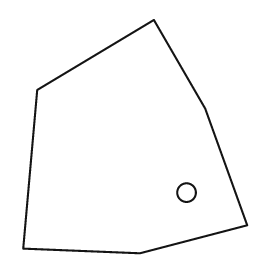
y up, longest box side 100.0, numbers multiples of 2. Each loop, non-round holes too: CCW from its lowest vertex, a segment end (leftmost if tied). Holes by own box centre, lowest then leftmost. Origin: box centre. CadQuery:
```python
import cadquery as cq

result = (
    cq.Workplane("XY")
    .moveTo(2.0, -50.0)
    .lineTo(48.0, -38.0)
    .lineTo(30.0, 12.0)
    .lineTo(8.0, 50.0)
    .lineTo(-42.0, 20.0)
    .lineTo(-48.0, -48.0)
    .close()
    .moveTo(22.0, -24.0)
    .circle(4.0)
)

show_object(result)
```